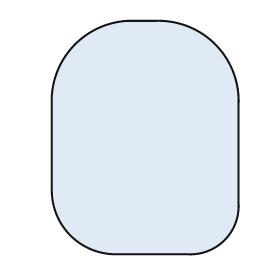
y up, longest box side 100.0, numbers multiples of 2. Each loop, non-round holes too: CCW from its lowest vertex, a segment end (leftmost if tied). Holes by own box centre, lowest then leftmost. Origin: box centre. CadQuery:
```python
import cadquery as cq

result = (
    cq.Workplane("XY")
    .moveTo(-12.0, -50.0)
    .lineTo(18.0, -50.0)
    .threePointArc((34.0, -44.0), (40.0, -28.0))
    .lineTo(40.0, 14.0)
    .threePointArc((30.0, 40.0), (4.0, 50.0))
    .lineTo(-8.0, 50.0)
    .threePointArc((-30.0, 40.0), (-40.0, 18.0))
    .lineTo(-40.0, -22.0)
    .threePointArc((-32.0, -42.0), (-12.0, -50.0))
    .close()
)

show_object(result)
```